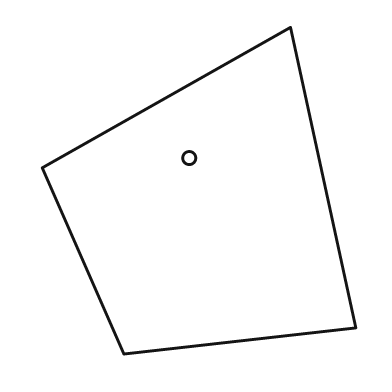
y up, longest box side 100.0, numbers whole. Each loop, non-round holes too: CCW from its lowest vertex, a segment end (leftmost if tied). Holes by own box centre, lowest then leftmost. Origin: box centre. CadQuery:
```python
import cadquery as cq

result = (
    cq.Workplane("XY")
    .moveTo(-23.0, -50.0)
    .lineTo(48.0, -42.0)
    .lineTo(28.0, 50.0)
    .lineTo(-48.0, 7.0)
    .close()
    .moveTo(-3.0, 10.0)
    .circle(2.0)
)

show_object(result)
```